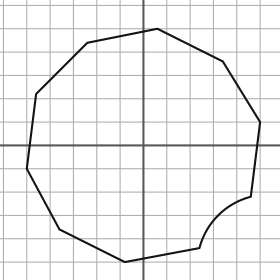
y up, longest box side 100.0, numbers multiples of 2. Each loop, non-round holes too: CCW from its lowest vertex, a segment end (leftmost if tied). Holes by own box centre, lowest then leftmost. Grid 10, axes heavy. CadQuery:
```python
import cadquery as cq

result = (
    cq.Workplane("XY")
    .moveTo(-8.0, -50.0)
    .lineTo(24.0, -44.0)
    .threePointArc((32.0, -30.0), (46.0, -22.0))
    .lineTo(50.0, 10.0)
    .lineTo(34.0, 36.0)
    .lineTo(6.0, 50.0)
    .lineTo(-24.0, 44.0)
    .lineTo(-46.0, 22.0)
    .lineTo(-50.0, -10.0)
    .lineTo(-36.0, -36.0)
    .close()
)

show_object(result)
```